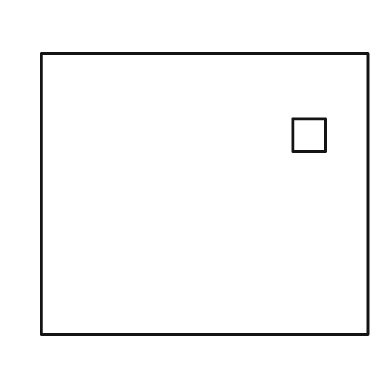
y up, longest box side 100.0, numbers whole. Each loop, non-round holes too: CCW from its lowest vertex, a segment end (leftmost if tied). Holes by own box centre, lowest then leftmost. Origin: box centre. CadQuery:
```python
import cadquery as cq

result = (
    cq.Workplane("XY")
    .moveTo(-50.0, -43.0)
    .lineTo(50.0, -43.0)
    .lineTo(50.0, 43.0)
    .lineTo(-50.0, 43.0)
    .close()
    .moveTo(27.0, 13.0)
    .lineTo(37.0, 13.0)
    .lineTo(37.0, 23.0)
    .lineTo(27.0, 23.0)
    .close()
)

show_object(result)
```